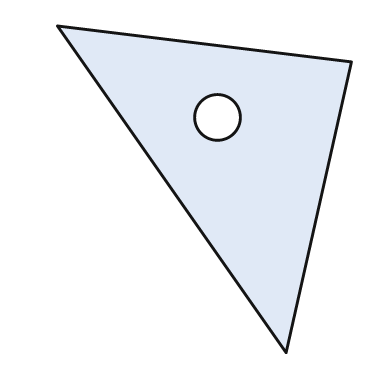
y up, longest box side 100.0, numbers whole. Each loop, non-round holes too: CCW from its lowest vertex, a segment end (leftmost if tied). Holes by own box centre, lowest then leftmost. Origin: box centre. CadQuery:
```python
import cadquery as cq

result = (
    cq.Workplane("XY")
    .moveTo(25.0, -50.0)
    .lineTo(45.0, 39.0)
    .lineTo(-45.0, 50.0)
    .close()
    .moveTo(4.0, 22.0)
    .circle(7.0)
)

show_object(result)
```